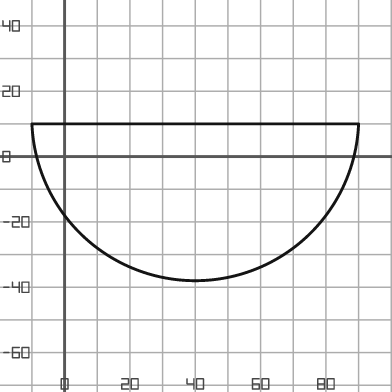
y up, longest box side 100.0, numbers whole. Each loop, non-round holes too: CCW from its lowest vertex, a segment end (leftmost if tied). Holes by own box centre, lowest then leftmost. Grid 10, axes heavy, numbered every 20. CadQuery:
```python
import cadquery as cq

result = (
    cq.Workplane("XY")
    .moveTo(-10.0, 10.0)
    .threePointArc((40.0, -38.0), (90.0, 10.0))
    .close()
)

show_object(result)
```